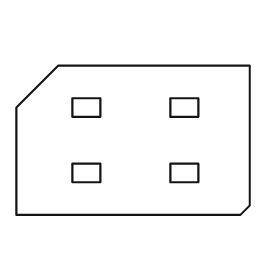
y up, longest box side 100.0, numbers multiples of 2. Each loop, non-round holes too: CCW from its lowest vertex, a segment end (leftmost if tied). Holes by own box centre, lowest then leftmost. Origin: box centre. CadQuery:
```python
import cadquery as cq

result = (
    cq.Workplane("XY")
    .moveTo(-50.0, -32.0)
    .lineTo(46.0, -32.0)
    .lineTo(50.0, -28.0)
    .lineTo(50.0, 32.0)
    .lineTo(-32.0, 32.0)
    .lineTo(-50.0, 14.0)
    .close()
    .moveTo(-26.0, -18.0)
    .lineTo(-14.0, -18.0)
    .lineTo(-14.0, -10.0)
    .lineTo(-26.0, -10.0)
    .close()
    .moveTo(16.0, -18.0)
    .lineTo(28.0, -18.0)
    .lineTo(28.0, -10.0)
    .lineTo(16.0, -10.0)
    .close()
    .moveTo(-26.0, 10.0)
    .lineTo(-14.0, 10.0)
    .lineTo(-14.0, 18.0)
    .lineTo(-26.0, 18.0)
    .close()
    .moveTo(16.0, 10.0)
    .lineTo(28.0, 10.0)
    .lineTo(28.0, 18.0)
    .lineTo(16.0, 18.0)
    .close()
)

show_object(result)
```